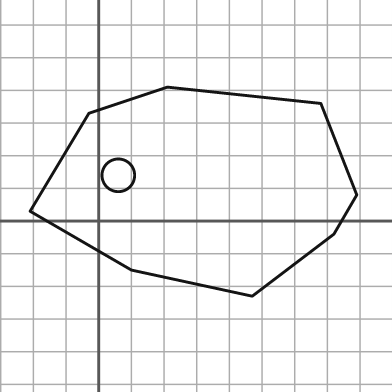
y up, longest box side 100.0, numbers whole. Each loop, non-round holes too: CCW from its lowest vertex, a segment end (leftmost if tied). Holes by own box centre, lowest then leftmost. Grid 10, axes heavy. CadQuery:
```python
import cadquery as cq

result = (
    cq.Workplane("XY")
    .moveTo(47.0, -23.0)
    .lineTo(72.0, -4.0)
    .lineTo(79.0, 8.0)
    .lineTo(68.0, 36.0)
    .lineTo(21.0, 41.0)
    .lineTo(-3.0, 33.0)
    .lineTo(-21.0, 3.0)
    .lineTo(10.0, -15.0)
    .close()
    .moveTo(6.0, 14.0)
    .circle(5.0)
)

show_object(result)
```